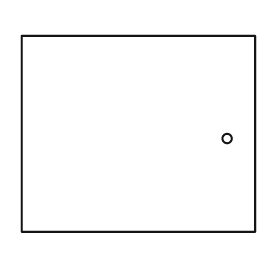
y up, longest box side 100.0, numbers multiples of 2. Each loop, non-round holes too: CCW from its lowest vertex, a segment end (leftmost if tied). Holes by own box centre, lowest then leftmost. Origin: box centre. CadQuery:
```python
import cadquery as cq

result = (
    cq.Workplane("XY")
    .moveTo(-50.0, -42.0)
    .lineTo(50.0, -42.0)
    .lineTo(50.0, 42.0)
    .lineTo(-50.0, 42.0)
    .close()
    .moveTo(38.0, -2.0)
    .circle(2.0)
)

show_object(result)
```